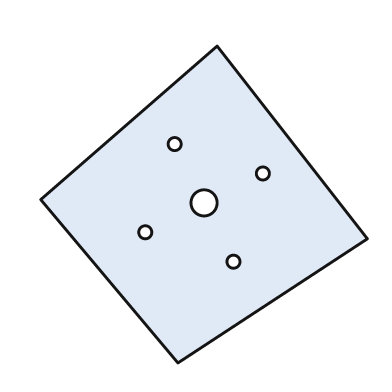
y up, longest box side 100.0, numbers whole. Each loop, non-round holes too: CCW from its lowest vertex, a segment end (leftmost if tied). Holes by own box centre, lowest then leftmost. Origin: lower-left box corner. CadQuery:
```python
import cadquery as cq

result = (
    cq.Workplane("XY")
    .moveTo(42.0, 0.0)
    .lineTo(100.0, 38.0)
    .lineTo(54.0, 97.0)
    .lineTo(0.0, 50.0)
    .close()
    .moveTo(59.0, 31.0)
    .circle(2.0)
    .moveTo(32.0, 40.0)
    .circle(2.0)
    .moveTo(50.0, 49.0)
    .circle(4.0)
    .moveTo(68.0, 58.0)
    .circle(2.0)
    .moveTo(41.0, 67.0)
    .circle(2.0)
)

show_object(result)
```